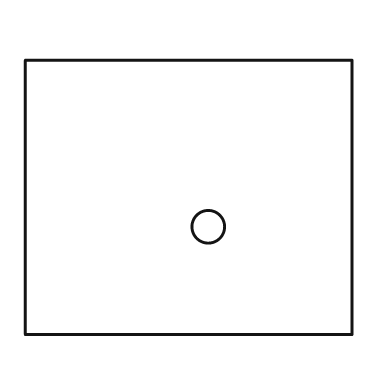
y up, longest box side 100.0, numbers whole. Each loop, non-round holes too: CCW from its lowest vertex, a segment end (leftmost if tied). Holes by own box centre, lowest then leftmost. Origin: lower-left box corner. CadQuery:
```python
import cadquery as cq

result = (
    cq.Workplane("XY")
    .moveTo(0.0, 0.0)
    .lineTo(100.0, 0.0)
    .lineTo(100.0, 84.0)
    .lineTo(0.0, 84.0)
    .close()
    .moveTo(56.0, 33.0)
    .circle(5.0)
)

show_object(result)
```